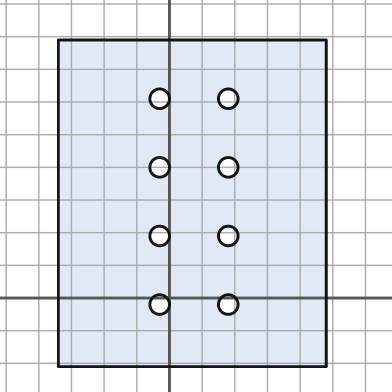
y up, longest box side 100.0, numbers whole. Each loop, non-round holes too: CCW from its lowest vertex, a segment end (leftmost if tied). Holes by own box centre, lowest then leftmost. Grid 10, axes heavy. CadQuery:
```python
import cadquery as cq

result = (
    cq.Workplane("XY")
    .moveTo(-34.0, -21.0)
    .lineTo(48.0, -21.0)
    .lineTo(48.0, 79.0)
    .lineTo(-34.0, 79.0)
    .close()
    .moveTo(-3.0, -2.0)
    .circle(3.0)
    .moveTo(18.0, -2.0)
    .circle(3.0)
    .moveTo(-3.0, 19.0)
    .circle(3.0)
    .moveTo(18.0, 19.0)
    .circle(3.0)
    .moveTo(-3.0, 40.0)
    .circle(3.0)
    .moveTo(18.0, 40.0)
    .circle(3.0)
    .moveTo(-3.0, 61.0)
    .circle(3.0)
    .moveTo(18.0, 61.0)
    .circle(3.0)
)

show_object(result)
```